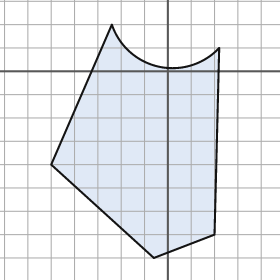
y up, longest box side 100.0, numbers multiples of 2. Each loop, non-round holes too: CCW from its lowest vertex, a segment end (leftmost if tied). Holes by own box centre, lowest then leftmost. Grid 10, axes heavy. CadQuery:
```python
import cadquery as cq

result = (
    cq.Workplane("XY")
    .moveTo(-6.0, -80.0)
    .lineTo(20.0, -70.0)
    .lineTo(22.0, 10.0)
    .threePointArc((-4.0, 2.0), (-24.0, 20.0))
    .lineTo(-50.0, -40.0)
    .close()
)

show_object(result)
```